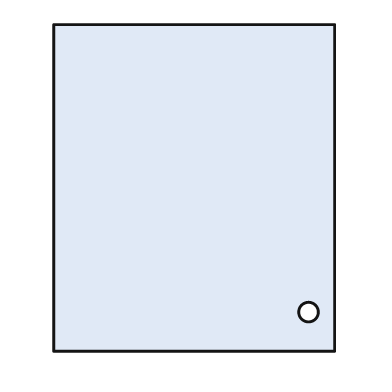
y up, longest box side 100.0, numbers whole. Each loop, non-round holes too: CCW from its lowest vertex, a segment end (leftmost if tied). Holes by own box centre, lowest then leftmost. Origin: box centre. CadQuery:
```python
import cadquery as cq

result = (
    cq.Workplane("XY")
    .moveTo(-43.0, -50.0)
    .lineTo(43.0, -50.0)
    .lineTo(43.0, 50.0)
    .lineTo(-43.0, 50.0)
    .close()
    .moveTo(35.0, -38.0)
    .circle(3.0)
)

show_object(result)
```